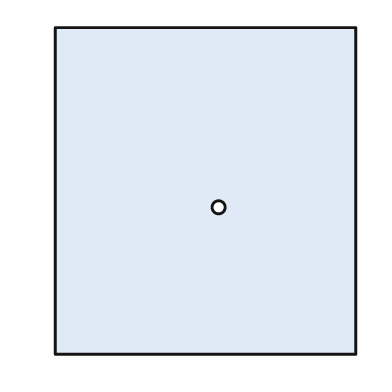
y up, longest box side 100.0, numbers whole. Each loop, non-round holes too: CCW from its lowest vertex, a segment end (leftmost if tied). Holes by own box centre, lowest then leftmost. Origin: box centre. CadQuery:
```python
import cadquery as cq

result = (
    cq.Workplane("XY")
    .moveTo(-46.0, -50.0)
    .lineTo(46.0, -50.0)
    .lineTo(46.0, 50.0)
    .lineTo(-46.0, 50.0)
    .close()
    .moveTo(4.0, -5.0)
    .circle(2.0)
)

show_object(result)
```